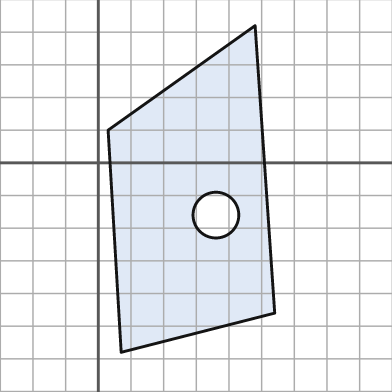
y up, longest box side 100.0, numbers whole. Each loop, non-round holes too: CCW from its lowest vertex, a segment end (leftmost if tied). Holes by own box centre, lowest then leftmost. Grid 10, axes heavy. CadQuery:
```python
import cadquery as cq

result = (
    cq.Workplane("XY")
    .moveTo(7.0, -58.0)
    .lineTo(54.0, -46.0)
    .lineTo(48.0, 42.0)
    .lineTo(3.0, 10.0)
    .close()
    .moveTo(36.0, -16.0)
    .circle(7.0)
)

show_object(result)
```